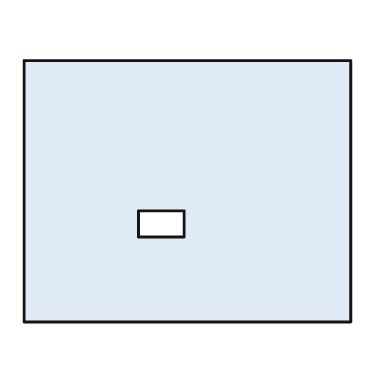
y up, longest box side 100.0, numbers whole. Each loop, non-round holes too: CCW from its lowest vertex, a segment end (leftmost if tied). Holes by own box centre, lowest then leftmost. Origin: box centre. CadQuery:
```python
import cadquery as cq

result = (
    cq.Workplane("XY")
    .moveTo(-50.0, -40.0)
    .lineTo(50.0, -40.0)
    .lineTo(50.0, 40.0)
    .lineTo(-50.0, 40.0)
    .close()
    .moveTo(-15.0, -14.0)
    .lineTo(-1.0, -14.0)
    .lineTo(-1.0, -6.0)
    .lineTo(-15.0, -6.0)
    .close()
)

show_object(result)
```